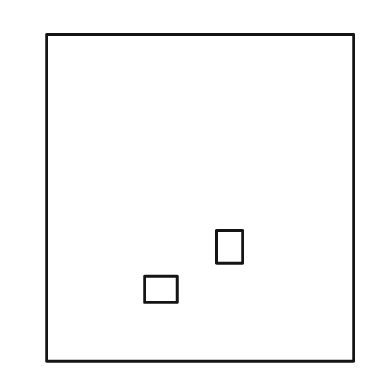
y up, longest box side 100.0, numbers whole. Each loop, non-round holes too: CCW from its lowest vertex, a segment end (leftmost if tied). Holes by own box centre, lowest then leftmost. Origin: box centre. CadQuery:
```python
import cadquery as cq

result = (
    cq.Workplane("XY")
    .moveTo(-47.0, -50.0)
    .lineTo(47.0, -50.0)
    .lineTo(47.0, 50.0)
    .lineTo(-47.0, 50.0)
    .close()
    .moveTo(-17.0, -32.0)
    .lineTo(-7.0, -32.0)
    .lineTo(-7.0, -24.0)
    .lineTo(-17.0, -24.0)
    .close()
    .moveTo(5.0, -20.0)
    .lineTo(13.0, -20.0)
    .lineTo(13.0, -10.0)
    .lineTo(5.0, -10.0)
    .close()
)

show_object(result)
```